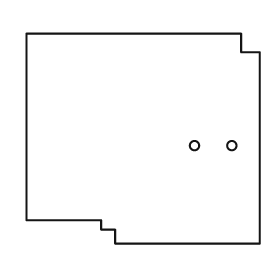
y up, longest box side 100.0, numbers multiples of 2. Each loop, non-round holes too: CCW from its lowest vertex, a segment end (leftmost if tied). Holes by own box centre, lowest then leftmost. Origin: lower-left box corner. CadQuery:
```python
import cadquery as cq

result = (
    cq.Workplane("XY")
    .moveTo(38.0, 0.0)
    .lineTo(100.0, 0.0)
    .lineTo(100.0, 82.0)
    .lineTo(92.0, 82.0)
    .lineTo(92.0, 90.0)
    .lineTo(0.0, 90.0)
    .lineTo(0.0, 10.0)
    .lineTo(32.0, 10.0)
    .lineTo(32.0, 6.0)
    .lineTo(38.0, 6.0)
    .close()
    .moveTo(72.0, 42.0)
    .circle(2.0)
    .moveTo(88.0, 42.0)
    .circle(2.0)
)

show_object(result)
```